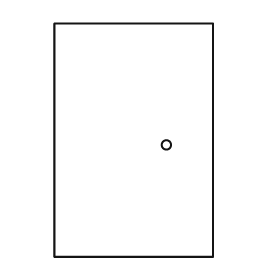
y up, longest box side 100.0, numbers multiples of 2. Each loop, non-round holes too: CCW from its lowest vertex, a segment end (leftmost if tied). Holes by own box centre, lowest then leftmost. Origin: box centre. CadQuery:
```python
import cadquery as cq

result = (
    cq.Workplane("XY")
    .moveTo(-34.0, -50.0)
    .lineTo(34.0, -50.0)
    .lineTo(34.0, 50.0)
    .lineTo(-34.0, 50.0)
    .close()
    .moveTo(14.0, -2.0)
    .circle(2.0)
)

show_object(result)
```